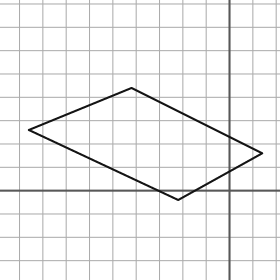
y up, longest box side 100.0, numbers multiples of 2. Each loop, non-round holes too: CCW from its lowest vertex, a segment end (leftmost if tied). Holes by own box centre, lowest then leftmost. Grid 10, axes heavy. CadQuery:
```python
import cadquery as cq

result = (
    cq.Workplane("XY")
    .moveTo(-22.0, -4.0)
    .lineTo(14.0, 16.0)
    .lineTo(-42.0, 44.0)
    .lineTo(-86.0, 26.0)
    .close()
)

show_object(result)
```